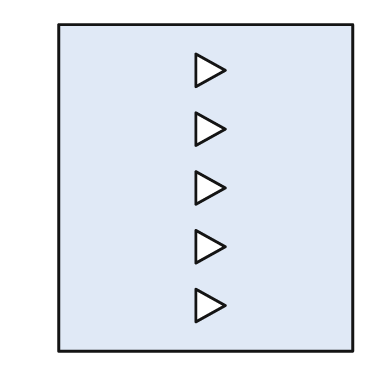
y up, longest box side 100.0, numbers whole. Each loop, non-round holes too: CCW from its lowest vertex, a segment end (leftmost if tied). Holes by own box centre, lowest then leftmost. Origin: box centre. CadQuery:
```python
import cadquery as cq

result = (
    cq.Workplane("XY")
    .moveTo(-45.0, -50.0)
    .lineTo(45.0, -50.0)
    .lineTo(45.0, 50.0)
    .lineTo(-45.0, 50.0)
    .close()
    .moveTo(-3.0, -41.0)
    .lineTo(6.0, -36.0)
    .lineTo(-3.0, -31.0)
    .close()
    .moveTo(-3.0, -23.0)
    .lineTo(6.0, -18.0)
    .lineTo(-3.0, -13.0)
    .close()
    .moveTo(-3.0, -5.0)
    .lineTo(6.0, 0.0)
    .lineTo(-3.0, 5.0)
    .close()
    .moveTo(-3.0, 13.0)
    .lineTo(6.0, 18.0)
    .lineTo(-3.0, 23.0)
    .close()
    .moveTo(-3.0, 31.0)
    .lineTo(6.0, 36.0)
    .lineTo(-3.0, 41.0)
    .close()
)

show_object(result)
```